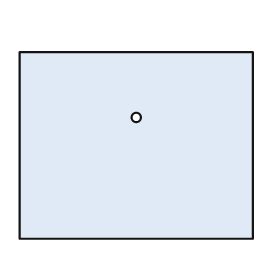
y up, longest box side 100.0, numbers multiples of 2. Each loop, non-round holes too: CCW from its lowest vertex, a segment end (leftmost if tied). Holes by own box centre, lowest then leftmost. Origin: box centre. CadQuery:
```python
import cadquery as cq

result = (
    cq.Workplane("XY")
    .moveTo(-50.0, -40.0)
    .lineTo(50.0, -40.0)
    .lineTo(50.0, 40.0)
    .lineTo(-50.0, 40.0)
    .close()
    .moveTo(0.0, 12.0)
    .circle(2.0)
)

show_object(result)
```